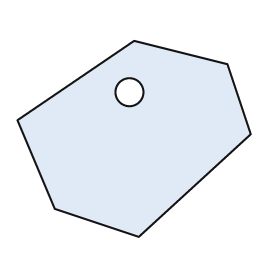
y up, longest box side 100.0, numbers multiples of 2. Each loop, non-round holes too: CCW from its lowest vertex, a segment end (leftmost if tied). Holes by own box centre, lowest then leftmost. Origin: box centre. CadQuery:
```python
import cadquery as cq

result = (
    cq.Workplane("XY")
    .moveTo(2.0, -42.0)
    .lineTo(50.0, 2.0)
    .lineTo(40.0, 32.0)
    .lineTo(0.0, 42.0)
    .lineTo(-50.0, 8.0)
    .lineTo(-34.0, -30.0)
    .close()
    .moveTo(-2.0, 20.0)
    .circle(6.0)
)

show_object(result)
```